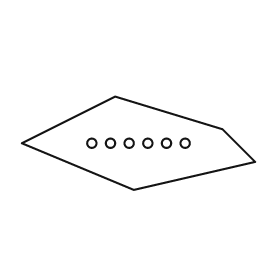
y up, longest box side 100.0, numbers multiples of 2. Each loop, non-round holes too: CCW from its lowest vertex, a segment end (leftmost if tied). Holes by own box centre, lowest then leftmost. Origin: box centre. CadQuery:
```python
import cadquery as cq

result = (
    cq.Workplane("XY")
    .moveTo(-2.0, -20.0)
    .lineTo(50.0, -8.0)
    .lineTo(36.0, 6.0)
    .lineTo(-10.0, 20.0)
    .lineTo(-50.0, 0.0)
    .close()
    .moveTo(-20.0, 0.0)
    .circle(2.0)
    .moveTo(-12.0, 0.0)
    .circle(2.0)
    .moveTo(-4.0, 0.0)
    .circle(2.0)
    .moveTo(4.0, 0.0)
    .circle(2.0)
    .moveTo(12.0, 0.0)
    .circle(2.0)
    .moveTo(20.0, 0.0)
    .circle(2.0)
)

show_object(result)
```